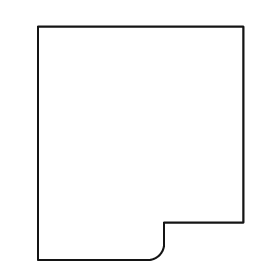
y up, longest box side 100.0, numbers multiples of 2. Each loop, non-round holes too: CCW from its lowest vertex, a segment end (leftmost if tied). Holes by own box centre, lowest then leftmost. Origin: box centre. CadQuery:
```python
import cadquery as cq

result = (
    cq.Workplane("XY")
    .moveTo(-44.0, -50.0)
    .lineTo(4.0, -50.0)
    .threePointArc((8.0, -48.0), (10.0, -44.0))
    .lineTo(10.0, -34.0)
    .lineTo(44.0, -34.0)
    .lineTo(44.0, 50.0)
    .lineTo(-44.0, 50.0)
    .close()
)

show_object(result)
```